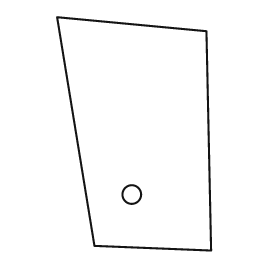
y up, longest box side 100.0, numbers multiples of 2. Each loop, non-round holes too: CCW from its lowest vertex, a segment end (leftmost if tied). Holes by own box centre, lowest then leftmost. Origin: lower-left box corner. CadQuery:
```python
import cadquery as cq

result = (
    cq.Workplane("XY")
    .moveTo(66.0, 0.0)
    .lineTo(64.0, 94.0)
    .lineTo(0.0, 100.0)
    .lineTo(16.0, 2.0)
    .close()
    .moveTo(32.0, 24.0)
    .circle(4.0)
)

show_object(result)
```